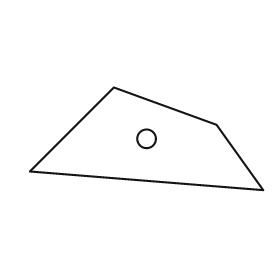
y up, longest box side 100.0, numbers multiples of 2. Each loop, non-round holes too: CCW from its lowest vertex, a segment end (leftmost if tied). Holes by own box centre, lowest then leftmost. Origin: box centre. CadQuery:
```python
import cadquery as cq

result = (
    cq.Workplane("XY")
    .moveTo(50.0, -22.0)
    .lineTo(30.0, 6.0)
    .lineTo(-14.0, 22.0)
    .lineTo(-50.0, -14.0)
    .close()
    .moveTo(0.0, 0.0)
    .circle(4.0)
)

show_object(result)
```